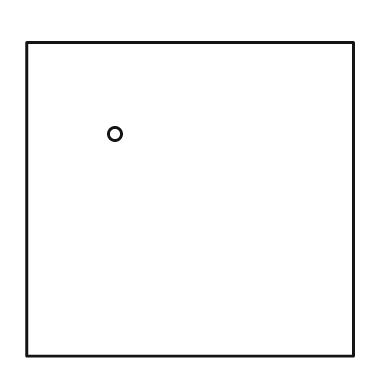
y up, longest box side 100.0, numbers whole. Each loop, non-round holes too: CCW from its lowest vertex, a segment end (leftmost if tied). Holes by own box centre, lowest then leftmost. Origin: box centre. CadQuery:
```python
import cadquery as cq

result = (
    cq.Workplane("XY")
    .moveTo(-50.0, -48.0)
    .lineTo(50.0, -48.0)
    .lineTo(50.0, 48.0)
    .lineTo(-50.0, 48.0)
    .close()
    .moveTo(-23.0, 20.0)
    .circle(2.0)
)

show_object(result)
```